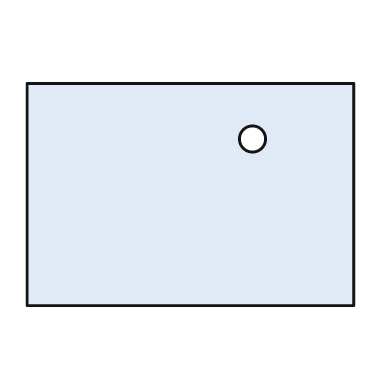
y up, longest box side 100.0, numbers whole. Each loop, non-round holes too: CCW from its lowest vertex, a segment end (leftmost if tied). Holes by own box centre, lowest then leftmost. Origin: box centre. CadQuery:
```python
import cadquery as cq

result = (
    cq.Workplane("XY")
    .moveTo(-50.0, -34.0)
    .lineTo(50.0, -34.0)
    .lineTo(50.0, 34.0)
    .lineTo(-50.0, 34.0)
    .close()
    .moveTo(19.0, 17.0)
    .circle(4.0)
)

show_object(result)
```